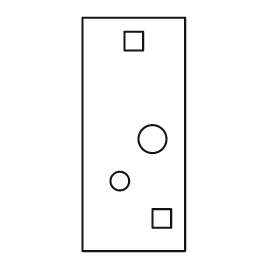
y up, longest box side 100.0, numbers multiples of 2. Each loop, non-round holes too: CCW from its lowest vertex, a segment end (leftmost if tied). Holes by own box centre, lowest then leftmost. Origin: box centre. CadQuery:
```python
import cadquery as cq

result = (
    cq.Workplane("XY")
    .moveTo(-22.0, -50.0)
    .lineTo(22.0, -50.0)
    .lineTo(22.0, 50.0)
    .lineTo(-22.0, 50.0)
    .close()
    .moveTo(8.0, -40.0)
    .lineTo(16.0, -40.0)
    .lineTo(16.0, -32.0)
    .lineTo(8.0, -32.0)
    .close()
    .moveTo(-6.0, -20.0)
    .circle(4.0)
    .moveTo(8.0, -2.0)
    .circle(6.0)
    .moveTo(-4.0, 36.0)
    .lineTo(4.0, 36.0)
    .lineTo(4.0, 44.0)
    .lineTo(-4.0, 44.0)
    .close()
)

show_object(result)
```